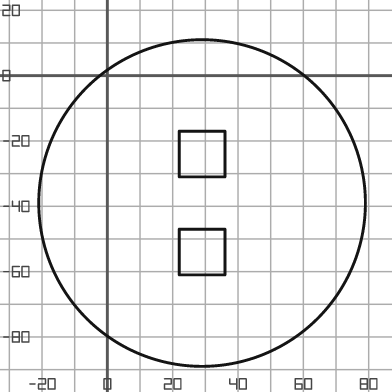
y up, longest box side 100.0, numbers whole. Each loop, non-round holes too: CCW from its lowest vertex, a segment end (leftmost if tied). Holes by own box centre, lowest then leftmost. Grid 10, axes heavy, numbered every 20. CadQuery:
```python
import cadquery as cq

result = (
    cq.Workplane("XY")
    .moveTo(29.0, -39.0)
    .circle(50.0)
    .moveTo(22.0, -61.0)
    .lineTo(36.0, -61.0)
    .lineTo(36.0, -47.0)
    .lineTo(22.0, -47.0)
    .close()
    .moveTo(22.0, -31.0)
    .lineTo(36.0, -31.0)
    .lineTo(36.0, -17.0)
    .lineTo(22.0, -17.0)
    .close()
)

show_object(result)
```